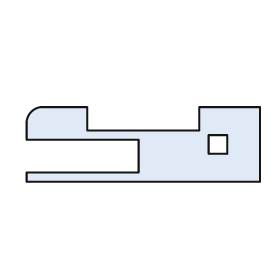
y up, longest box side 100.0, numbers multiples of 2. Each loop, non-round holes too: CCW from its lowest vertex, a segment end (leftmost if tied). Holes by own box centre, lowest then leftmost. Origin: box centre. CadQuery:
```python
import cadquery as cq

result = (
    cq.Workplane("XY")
    .moveTo(-50.0, -16.0)
    .lineTo(50.0, -16.0)
    .lineTo(50.0, 16.0)
    .lineTo(24.0, 16.0)
    .lineTo(24.0, 6.0)
    .lineTo(-24.0, 6.0)
    .lineTo(-24.0, 16.0)
    .lineTo(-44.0, 16.0)
    .threePointArc((-48.0, 14.0), (-50.0, 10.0))
    .lineTo(-50.0, 2.0)
    .lineTo(-2.0, 2.0)
    .lineTo(-2.0, -12.0)
    .lineTo(-50.0, -12.0)
    .close()
    .moveTo(28.0, -4.0)
    .lineTo(36.0, -4.0)
    .lineTo(36.0, 4.0)
    .lineTo(28.0, 4.0)
    .close()
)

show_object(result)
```